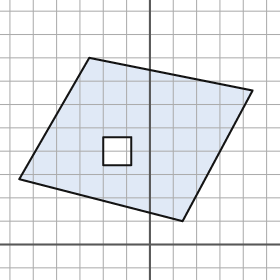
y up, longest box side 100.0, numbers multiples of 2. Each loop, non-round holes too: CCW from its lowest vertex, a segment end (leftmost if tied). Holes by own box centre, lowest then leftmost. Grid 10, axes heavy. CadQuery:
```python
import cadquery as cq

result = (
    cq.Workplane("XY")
    .moveTo(14.0, 10.0)
    .lineTo(44.0, 66.0)
    .lineTo(-26.0, 80.0)
    .lineTo(-56.0, 28.0)
    .close()
    .moveTo(-20.0, 34.0)
    .lineTo(-8.0, 34.0)
    .lineTo(-8.0, 46.0)
    .lineTo(-20.0, 46.0)
    .close()
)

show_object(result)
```